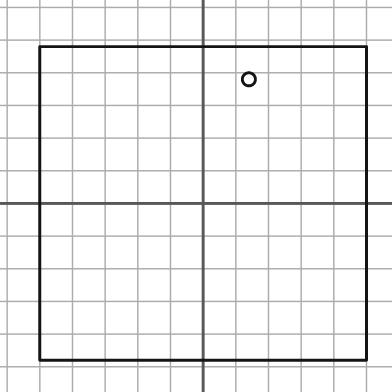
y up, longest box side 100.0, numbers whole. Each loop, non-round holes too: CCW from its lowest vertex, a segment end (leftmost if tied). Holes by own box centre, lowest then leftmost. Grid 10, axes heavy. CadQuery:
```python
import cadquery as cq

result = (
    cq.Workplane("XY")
    .moveTo(-50.0, -48.0)
    .lineTo(50.0, -48.0)
    .lineTo(50.0, 48.0)
    .lineTo(-50.0, 48.0)
    .close()
    .moveTo(14.0, 38.0)
    .circle(2.0)
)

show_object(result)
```